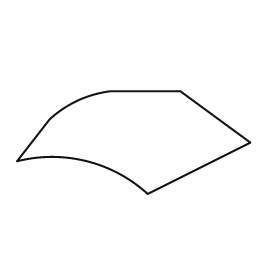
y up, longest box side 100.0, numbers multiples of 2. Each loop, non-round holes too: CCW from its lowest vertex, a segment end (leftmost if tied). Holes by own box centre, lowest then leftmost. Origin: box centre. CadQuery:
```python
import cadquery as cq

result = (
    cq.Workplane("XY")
    .moveTo(6.0, -22.0)
    .lineTo(50.0, 0.0)
    .lineTo(20.0, 22.0)
    .lineTo(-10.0, 22.0)
    .threePointArc((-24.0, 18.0), (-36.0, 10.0))
    .lineTo(-50.0, -8.0)
    .threePointArc((-20.0, -8.0), (6.0, -22.0))
    .close()
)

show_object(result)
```